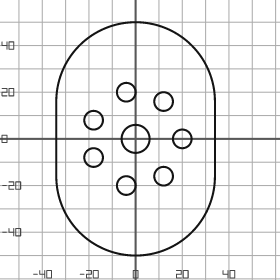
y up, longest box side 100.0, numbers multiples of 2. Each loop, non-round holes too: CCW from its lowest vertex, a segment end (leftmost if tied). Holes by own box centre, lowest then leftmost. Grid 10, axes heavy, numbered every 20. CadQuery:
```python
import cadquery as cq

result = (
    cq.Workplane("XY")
    .moveTo(-34.0, -16.0)
    .threePointArc((0.0, -50.0), (34.0, -16.0))
    .lineTo(34.0, 16.0)
    .threePointArc((0.0, 50.0), (-34.0, 16.0))
    .close()
    .moveTo(-4.0, -20.0)
    .circle(4.0)
    .moveTo(12.0, -16.0)
    .circle(4.0)
    .moveTo(-18.0, -8.0)
    .circle(4.0)
    .moveTo(0.0, 0.0)
    .circle(6.0)
    .moveTo(20.0, 0.0)
    .circle(4.0)
    .moveTo(-18.0, 8.0)
    .circle(4.0)
    .moveTo(12.0, 16.0)
    .circle(4.0)
    .moveTo(-4.0, 20.0)
    .circle(4.0)
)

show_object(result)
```